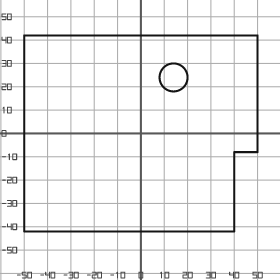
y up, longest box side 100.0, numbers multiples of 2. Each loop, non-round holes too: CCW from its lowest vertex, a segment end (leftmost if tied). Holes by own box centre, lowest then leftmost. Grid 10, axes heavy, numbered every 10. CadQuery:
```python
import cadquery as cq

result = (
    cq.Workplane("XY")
    .moveTo(-50.0, -42.0)
    .lineTo(40.0, -42.0)
    .lineTo(40.0, -8.0)
    .lineTo(50.0, -8.0)
    .lineTo(50.0, 42.0)
    .lineTo(-50.0, 42.0)
    .close()
    .moveTo(14.0, 24.0)
    .circle(6.0)
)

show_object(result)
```